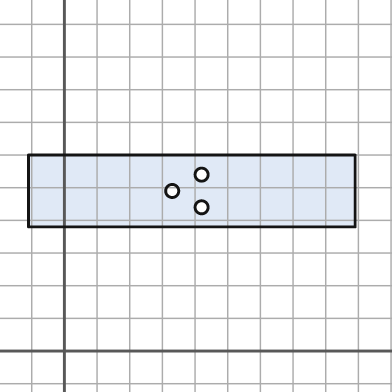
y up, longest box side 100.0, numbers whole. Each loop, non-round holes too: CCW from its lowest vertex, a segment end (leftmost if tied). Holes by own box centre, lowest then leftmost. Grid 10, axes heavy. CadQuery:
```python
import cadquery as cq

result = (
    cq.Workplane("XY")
    .moveTo(-11.0, 38.0)
    .lineTo(89.0, 38.0)
    .lineTo(89.0, 60.0)
    .lineTo(-11.0, 60.0)
    .close()
    .moveTo(42.0, 44.0)
    .circle(2.0)
    .moveTo(33.0, 49.0)
    .circle(2.0)
    .moveTo(42.0, 54.0)
    .circle(2.0)
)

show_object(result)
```